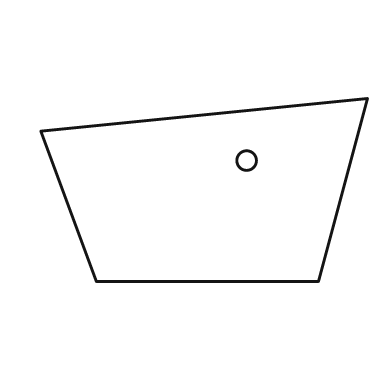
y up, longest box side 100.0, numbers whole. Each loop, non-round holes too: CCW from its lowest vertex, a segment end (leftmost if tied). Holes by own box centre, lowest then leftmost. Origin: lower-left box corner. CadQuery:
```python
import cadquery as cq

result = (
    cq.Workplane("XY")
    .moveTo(17.0, 0.0)
    .lineTo(85.0, 0.0)
    .lineTo(100.0, 56.0)
    .lineTo(0.0, 46.0)
    .close()
    .moveTo(63.0, 37.0)
    .circle(3.0)
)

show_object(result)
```